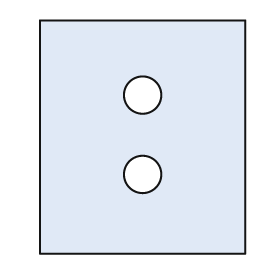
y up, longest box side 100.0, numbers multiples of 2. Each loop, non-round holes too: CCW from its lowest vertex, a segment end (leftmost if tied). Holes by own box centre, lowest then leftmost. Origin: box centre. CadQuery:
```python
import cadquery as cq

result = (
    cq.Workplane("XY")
    .moveTo(-44.0, -50.0)
    .lineTo(44.0, -50.0)
    .lineTo(44.0, 50.0)
    .lineTo(-44.0, 50.0)
    .close()
    .moveTo(0.0, -16.0)
    .circle(8.0)
    .moveTo(0.0, 18.0)
    .circle(8.0)
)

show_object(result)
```